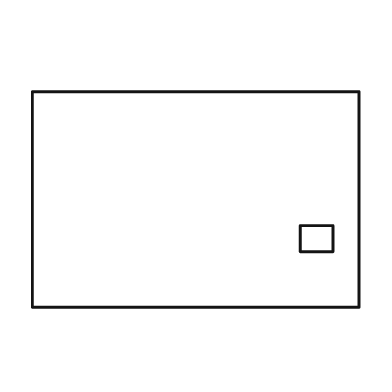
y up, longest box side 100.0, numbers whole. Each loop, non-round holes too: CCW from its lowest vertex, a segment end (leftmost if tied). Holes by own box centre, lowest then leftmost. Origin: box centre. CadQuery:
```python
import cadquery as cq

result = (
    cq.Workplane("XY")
    .moveTo(-50.0, -33.0)
    .lineTo(50.0, -33.0)
    .lineTo(50.0, 33.0)
    .lineTo(-50.0, 33.0)
    .close()
    .moveTo(32.0, -16.0)
    .lineTo(42.0, -16.0)
    .lineTo(42.0, -8.0)
    .lineTo(32.0, -8.0)
    .close()
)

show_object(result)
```